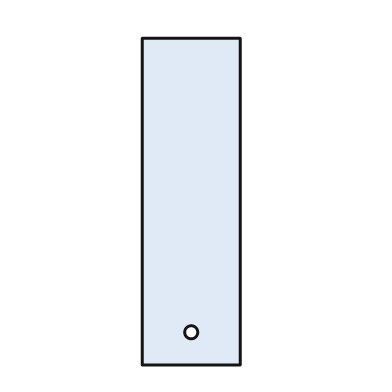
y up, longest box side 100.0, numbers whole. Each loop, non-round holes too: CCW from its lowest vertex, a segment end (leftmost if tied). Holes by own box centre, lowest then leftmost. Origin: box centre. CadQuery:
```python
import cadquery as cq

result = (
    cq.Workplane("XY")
    .moveTo(-15.0, -50.0)
    .lineTo(15.0, -50.0)
    .lineTo(15.0, 50.0)
    .lineTo(-15.0, 50.0)
    .close()
    .moveTo(0.0, -40.0)
    .circle(2.0)
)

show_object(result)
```